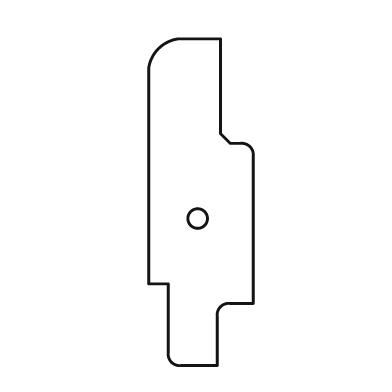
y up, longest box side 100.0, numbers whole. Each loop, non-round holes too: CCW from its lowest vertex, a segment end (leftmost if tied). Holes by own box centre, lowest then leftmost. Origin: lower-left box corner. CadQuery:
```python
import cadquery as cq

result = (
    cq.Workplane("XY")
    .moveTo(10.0, 0.0)
    .lineTo(21.0, 0.0)
    .lineTo(21.0, 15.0)
    .threePointArc((22.0, 18.0), (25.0, 19.0))
    .lineTo(32.0, 19.0)
    .lineTo(32.0, 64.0)
    .threePointArc((31.0, 67.0), (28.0, 68.0))
    .lineTo(25.0, 68.0)
    .lineTo(22.0, 71.0)
    .lineTo(22.0, 100.0)
    .lineTo(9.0, 100.0)
    .threePointArc((3.0, 97.0), (0.0, 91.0))
    .lineTo(0.0, 25.0)
    .lineTo(6.0, 25.0)
    .lineTo(6.0, 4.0)
    .threePointArc((7.0, 1.0), (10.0, 0.0))
    .close()
    .moveTo(15.0, 45.0)
    .circle(3.0)
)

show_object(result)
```